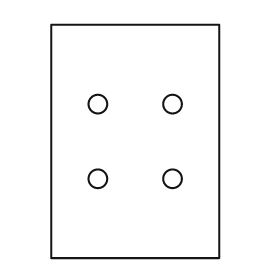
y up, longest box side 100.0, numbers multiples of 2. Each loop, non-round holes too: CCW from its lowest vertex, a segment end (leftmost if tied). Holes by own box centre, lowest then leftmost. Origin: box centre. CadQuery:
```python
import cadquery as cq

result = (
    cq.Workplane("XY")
    .moveTo(-36.0, -50.0)
    .lineTo(36.0, -50.0)
    .lineTo(36.0, 50.0)
    .lineTo(-36.0, 50.0)
    .close()
    .moveTo(-16.0, -16.0)
    .circle(4.0)
    .moveTo(16.0, -16.0)
    .circle(4.0)
    .moveTo(-16.0, 16.0)
    .circle(4.0)
    .moveTo(16.0, 16.0)
    .circle(4.0)
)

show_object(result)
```